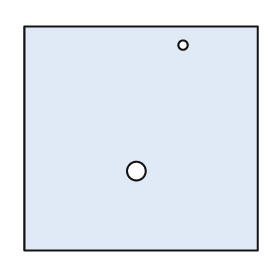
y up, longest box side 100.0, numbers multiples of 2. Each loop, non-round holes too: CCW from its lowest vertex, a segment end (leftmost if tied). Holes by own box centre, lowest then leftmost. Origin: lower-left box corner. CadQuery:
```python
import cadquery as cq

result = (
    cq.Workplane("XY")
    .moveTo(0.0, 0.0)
    .lineTo(100.0, 0.0)
    .lineTo(100.0, 96.0)
    .lineTo(0.0, 96.0)
    .close()
    .moveTo(48.0, 34.0)
    .circle(4.0)
    .moveTo(68.0, 88.0)
    .circle(2.0)
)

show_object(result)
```